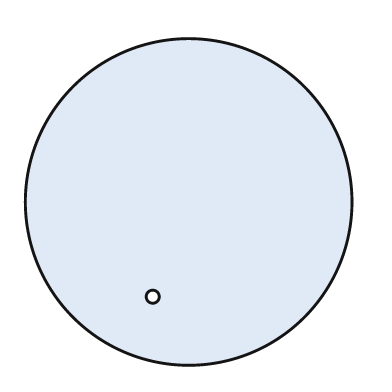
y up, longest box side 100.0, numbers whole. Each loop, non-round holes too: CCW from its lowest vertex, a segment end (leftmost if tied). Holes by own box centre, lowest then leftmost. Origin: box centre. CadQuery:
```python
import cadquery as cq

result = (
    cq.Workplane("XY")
    .moveTo(0.0, 0.0)
    .circle(50.0)
    .moveTo(-11.0, -29.0)
    .circle(2.0)
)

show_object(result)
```